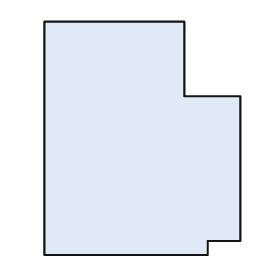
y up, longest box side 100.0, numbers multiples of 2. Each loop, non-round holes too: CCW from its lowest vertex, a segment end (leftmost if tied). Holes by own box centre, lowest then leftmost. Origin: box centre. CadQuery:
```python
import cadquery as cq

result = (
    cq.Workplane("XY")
    .moveTo(-42.0, -50.0)
    .lineTo(28.0, -50.0)
    .lineTo(28.0, -44.0)
    .lineTo(42.0, -44.0)
    .lineTo(42.0, 18.0)
    .lineTo(18.0, 18.0)
    .lineTo(18.0, 50.0)
    .lineTo(-42.0, 50.0)
    .close()
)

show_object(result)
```